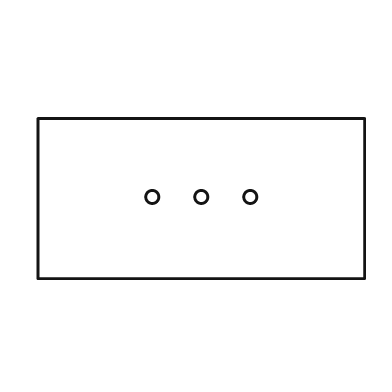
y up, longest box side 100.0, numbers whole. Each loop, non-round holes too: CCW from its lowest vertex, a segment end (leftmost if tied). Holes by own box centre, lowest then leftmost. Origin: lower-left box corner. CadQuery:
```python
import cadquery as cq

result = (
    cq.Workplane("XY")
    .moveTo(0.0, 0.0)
    .lineTo(100.0, 0.0)
    .lineTo(100.0, 49.0)
    .lineTo(0.0, 49.0)
    .close()
    .moveTo(35.0, 25.0)
    .circle(2.0)
    .moveTo(50.0, 25.0)
    .circle(2.0)
    .moveTo(65.0, 25.0)
    .circle(2.0)
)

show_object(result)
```